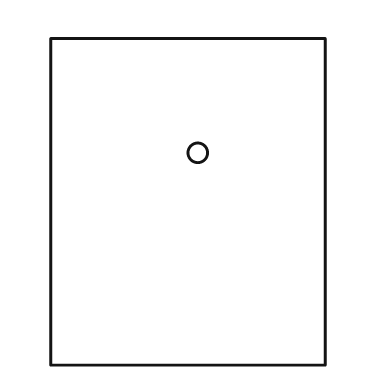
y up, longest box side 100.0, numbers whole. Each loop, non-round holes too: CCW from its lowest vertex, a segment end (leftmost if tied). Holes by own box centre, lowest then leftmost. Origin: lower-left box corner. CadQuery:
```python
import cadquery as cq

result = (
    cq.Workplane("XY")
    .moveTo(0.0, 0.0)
    .lineTo(84.0, 0.0)
    .lineTo(84.0, 100.0)
    .lineTo(0.0, 100.0)
    .close()
    .moveTo(45.0, 65.0)
    .circle(3.0)
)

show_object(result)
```